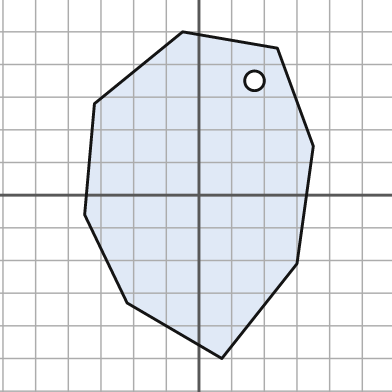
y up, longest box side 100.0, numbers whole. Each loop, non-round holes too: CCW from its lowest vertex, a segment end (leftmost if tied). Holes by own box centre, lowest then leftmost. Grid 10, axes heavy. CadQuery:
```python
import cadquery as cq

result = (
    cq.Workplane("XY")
    .moveTo(7.0, -50.0)
    .lineTo(30.0, -21.0)
    .lineTo(35.0, 15.0)
    .lineTo(24.0, 45.0)
    .lineTo(-5.0, 50.0)
    .lineTo(-32.0, 28.0)
    .lineTo(-35.0, -6.0)
    .lineTo(-22.0, -33.0)
    .close()
    .moveTo(17.0, 35.0)
    .circle(3.0)
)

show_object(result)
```